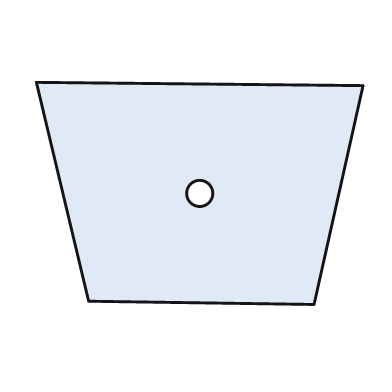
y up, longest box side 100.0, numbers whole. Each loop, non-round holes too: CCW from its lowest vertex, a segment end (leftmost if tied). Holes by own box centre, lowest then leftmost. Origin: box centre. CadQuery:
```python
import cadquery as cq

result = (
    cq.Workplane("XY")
    .moveTo(35.0, -34.0)
    .lineTo(50.0, 33.0)
    .lineTo(-50.0, 34.0)
    .lineTo(-34.0, -33.0)
    .close()
    .moveTo(0.0, 0.0)
    .circle(4.0)
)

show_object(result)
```